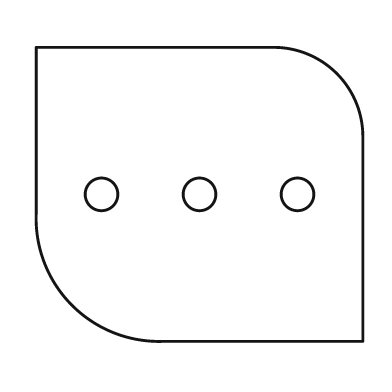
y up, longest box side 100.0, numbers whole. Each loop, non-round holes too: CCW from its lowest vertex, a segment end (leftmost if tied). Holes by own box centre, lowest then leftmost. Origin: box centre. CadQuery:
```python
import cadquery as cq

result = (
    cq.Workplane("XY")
    .moveTo(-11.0, -45.0)
    .lineTo(50.0, -45.0)
    .lineTo(50.0, 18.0)
    .threePointArc((42.0, 37.0), (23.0, 45.0))
    .lineTo(-50.0, 45.0)
    .lineTo(-50.0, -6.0)
    .threePointArc((-39.0, -34.0), (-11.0, -45.0))
    .close()
    .moveTo(-30.0, 0.0)
    .circle(5.0)
    .moveTo(0.0, 0.0)
    .circle(5.0)
    .moveTo(30.0, 0.0)
    .circle(5.0)
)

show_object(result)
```